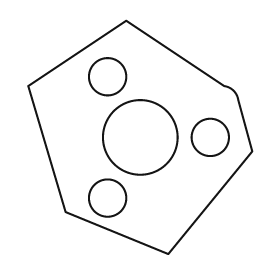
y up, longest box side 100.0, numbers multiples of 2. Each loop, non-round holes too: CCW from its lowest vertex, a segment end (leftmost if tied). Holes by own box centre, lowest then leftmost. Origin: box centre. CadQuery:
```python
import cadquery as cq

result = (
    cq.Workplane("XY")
    .moveTo(12.0, -50.0)
    .lineTo(48.0, -6.0)
    .lineTo(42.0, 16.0)
    .threePointArc((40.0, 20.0), (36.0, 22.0))
    .lineTo(-6.0, 50.0)
    .lineTo(-48.0, 22.0)
    .lineTo(-32.0, -32.0)
    .close()
    .moveTo(-14.0, -26.0)
    .circle(8.0)
    .moveTo(0.0, 0.0)
    .circle(16.0)
    .moveTo(30.0, 0.0)
    .circle(8.0)
    .moveTo(-14.0, 26.0)
    .circle(8.0)
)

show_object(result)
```